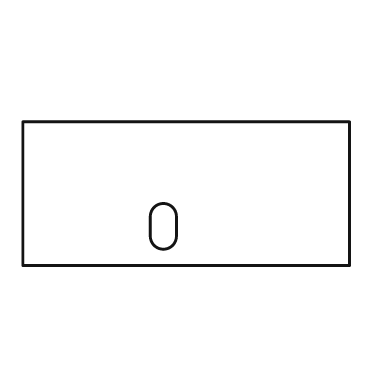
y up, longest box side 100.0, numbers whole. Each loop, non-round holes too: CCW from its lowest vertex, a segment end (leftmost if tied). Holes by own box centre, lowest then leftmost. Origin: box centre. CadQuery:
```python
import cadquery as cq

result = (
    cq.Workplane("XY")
    .moveTo(-50.0, -22.0)
    .lineTo(50.0, -22.0)
    .lineTo(50.0, 22.0)
    .lineTo(-50.0, 22.0)
    .close()
    .moveTo(-11.0, -13.0)
    .threePointArc((-7.0, -17.0), (-3.0, -13.0))
    .lineTo(-3.0, -7.0)
    .threePointArc((-7.0, -3.0), (-11.0, -7.0))
    .close()
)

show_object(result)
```